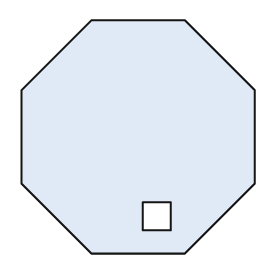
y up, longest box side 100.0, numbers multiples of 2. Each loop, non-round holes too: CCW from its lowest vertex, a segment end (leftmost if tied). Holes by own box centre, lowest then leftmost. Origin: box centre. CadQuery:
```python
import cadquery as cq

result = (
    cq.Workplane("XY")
    .moveTo(-20.0, -50.0)
    .lineTo(20.0, -50.0)
    .lineTo(50.0, -20.0)
    .lineTo(50.0, 20.0)
    .lineTo(20.0, 50.0)
    .lineTo(-20.0, 50.0)
    .lineTo(-50.0, 20.0)
    .lineTo(-50.0, -20.0)
    .close()
    .moveTo(2.0, -40.0)
    .lineTo(14.0, -40.0)
    .lineTo(14.0, -28.0)
    .lineTo(2.0, -28.0)
    .close()
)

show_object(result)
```